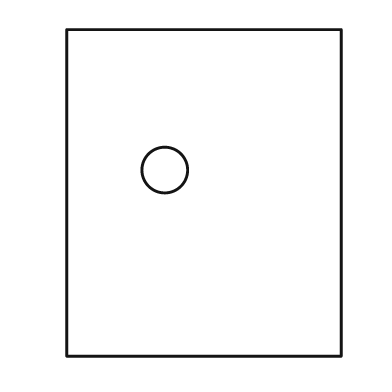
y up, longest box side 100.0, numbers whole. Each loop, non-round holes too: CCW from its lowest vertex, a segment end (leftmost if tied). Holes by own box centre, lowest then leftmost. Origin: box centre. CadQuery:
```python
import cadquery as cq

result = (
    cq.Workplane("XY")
    .moveTo(-42.0, -50.0)
    .lineTo(42.0, -50.0)
    .lineTo(42.0, 50.0)
    .lineTo(-42.0, 50.0)
    .close()
    .moveTo(-12.0, 7.0)
    .circle(7.0)
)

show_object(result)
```